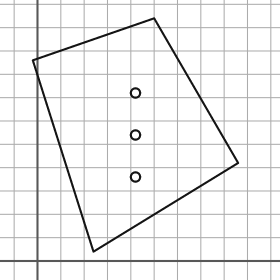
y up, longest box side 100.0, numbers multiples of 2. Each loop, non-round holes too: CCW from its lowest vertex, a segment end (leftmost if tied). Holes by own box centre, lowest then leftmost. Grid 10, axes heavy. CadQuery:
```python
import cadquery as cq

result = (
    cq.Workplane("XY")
    .moveTo(24.0, 4.0)
    .lineTo(86.0, 42.0)
    .lineTo(50.0, 104.0)
    .lineTo(-2.0, 86.0)
    .close()
    .moveTo(42.0, 36.0)
    .circle(2.0)
    .moveTo(42.0, 54.0)
    .circle(2.0)
    .moveTo(42.0, 72.0)
    .circle(2.0)
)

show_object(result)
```